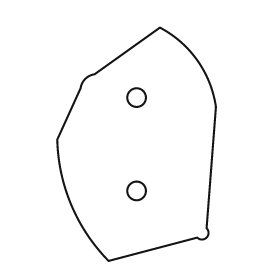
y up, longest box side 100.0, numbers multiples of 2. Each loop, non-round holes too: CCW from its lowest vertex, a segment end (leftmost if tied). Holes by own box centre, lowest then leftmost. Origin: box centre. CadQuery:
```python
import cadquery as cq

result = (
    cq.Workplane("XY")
    .moveTo(-12.0, -50.0)
    .lineTo(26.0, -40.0)
    .threePointArc((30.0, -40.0), (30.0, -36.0))
    .lineTo(34.0, 16.0)
    .threePointArc((26.0, 36.0), (10.0, 50.0))
    .lineTo(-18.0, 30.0)
    .threePointArc((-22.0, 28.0), (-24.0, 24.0))
    .lineTo(-34.0, 2.0)
    .threePointArc((-28.0, -26.0), (-12.0, -50.0))
    .close()
    .moveTo(0.0, -20.0)
    .circle(4.0)
    .moveTo(0.0, 20.0)
    .circle(4.0)
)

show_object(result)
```